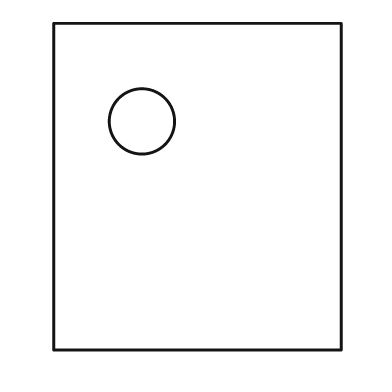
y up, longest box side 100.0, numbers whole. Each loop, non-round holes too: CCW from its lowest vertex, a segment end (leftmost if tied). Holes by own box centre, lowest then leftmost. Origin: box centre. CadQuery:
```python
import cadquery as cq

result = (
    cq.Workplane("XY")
    .moveTo(-44.0, -50.0)
    .lineTo(44.0, -50.0)
    .lineTo(44.0, 50.0)
    .lineTo(-44.0, 50.0)
    .close()
    .moveTo(-17.0, 20.0)
    .circle(10.0)
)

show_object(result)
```